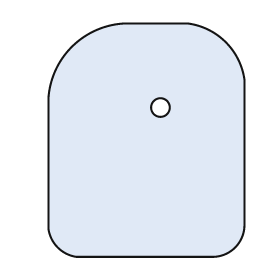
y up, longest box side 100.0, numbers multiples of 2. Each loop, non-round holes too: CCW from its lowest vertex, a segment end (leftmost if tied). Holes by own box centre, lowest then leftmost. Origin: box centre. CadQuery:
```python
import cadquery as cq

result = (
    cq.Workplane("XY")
    .moveTo(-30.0, -50.0)
    .lineTo(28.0, -50.0)
    .threePointArc((38.0, -46.0), (42.0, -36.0))
    .lineTo(42.0, 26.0)
    .threePointArc((34.0, 42.0), (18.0, 50.0))
    .lineTo(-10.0, 50.0)
    .threePointArc((-32.0, 40.0), (-42.0, 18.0))
    .lineTo(-42.0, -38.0)
    .threePointArc((-38.0, -46.0), (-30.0, -50.0))
    .close()
    .moveTo(6.0, 14.0)
    .circle(4.0)
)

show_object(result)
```